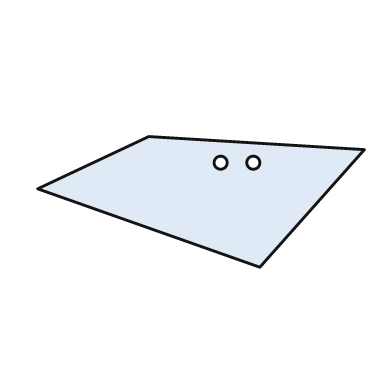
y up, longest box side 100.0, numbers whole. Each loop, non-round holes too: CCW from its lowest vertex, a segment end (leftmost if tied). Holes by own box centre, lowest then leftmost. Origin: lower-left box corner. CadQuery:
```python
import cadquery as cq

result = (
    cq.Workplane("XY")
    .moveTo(68.0, 0.0)
    .lineTo(100.0, 36.0)
    .lineTo(34.0, 40.0)
    .lineTo(0.0, 24.0)
    .close()
    .moveTo(56.0, 32.0)
    .circle(2.0)
    .moveTo(66.0, 32.0)
    .circle(2.0)
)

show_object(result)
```